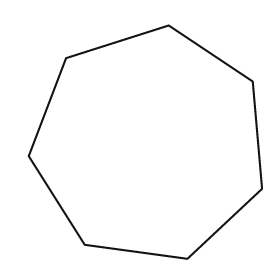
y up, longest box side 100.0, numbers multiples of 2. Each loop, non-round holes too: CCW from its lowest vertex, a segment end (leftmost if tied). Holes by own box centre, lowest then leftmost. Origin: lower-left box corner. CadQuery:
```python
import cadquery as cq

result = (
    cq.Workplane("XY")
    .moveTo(68.0, 0.0)
    .lineTo(100.0, 30.0)
    .lineTo(96.0, 76.0)
    .lineTo(60.0, 100.0)
    .lineTo(16.0, 86.0)
    .lineTo(0.0, 44.0)
    .lineTo(24.0, 6.0)
    .close()
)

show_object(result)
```